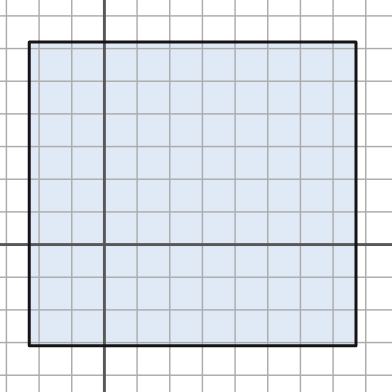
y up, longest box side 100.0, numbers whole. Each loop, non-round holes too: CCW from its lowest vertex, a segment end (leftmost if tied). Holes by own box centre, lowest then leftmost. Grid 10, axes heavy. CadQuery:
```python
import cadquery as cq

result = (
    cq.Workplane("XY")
    .moveTo(-23.0, -31.0)
    .lineTo(77.0, -31.0)
    .lineTo(77.0, 62.0)
    .lineTo(-23.0, 62.0)
    .close()
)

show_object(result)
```